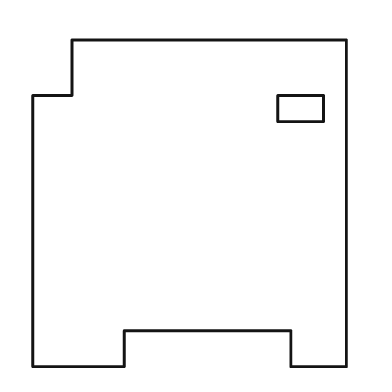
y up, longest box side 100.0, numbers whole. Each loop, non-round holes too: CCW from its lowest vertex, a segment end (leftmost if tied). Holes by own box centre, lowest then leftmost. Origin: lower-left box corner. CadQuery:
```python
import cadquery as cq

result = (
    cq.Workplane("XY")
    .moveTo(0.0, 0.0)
    .lineTo(28.0, 0.0)
    .lineTo(28.0, 11.0)
    .lineTo(79.0, 11.0)
    .lineTo(79.0, 0.0)
    .lineTo(96.0, 0.0)
    .lineTo(96.0, 100.0)
    .lineTo(12.0, 100.0)
    .lineTo(12.0, 83.0)
    .lineTo(0.0, 83.0)
    .close()
    .moveTo(75.0, 75.0)
    .lineTo(89.0, 75.0)
    .lineTo(89.0, 83.0)
    .lineTo(75.0, 83.0)
    .close()
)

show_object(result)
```